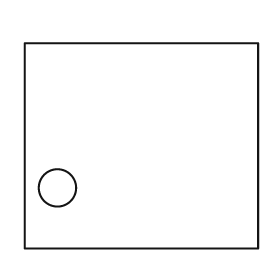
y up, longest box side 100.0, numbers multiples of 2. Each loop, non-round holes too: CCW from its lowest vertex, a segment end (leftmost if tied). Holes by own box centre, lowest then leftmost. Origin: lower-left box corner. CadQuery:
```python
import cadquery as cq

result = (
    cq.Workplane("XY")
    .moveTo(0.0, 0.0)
    .lineTo(100.0, 0.0)
    .lineTo(100.0, 88.0)
    .lineTo(0.0, 88.0)
    .close()
    .moveTo(14.0, 26.0)
    .circle(8.0)
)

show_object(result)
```